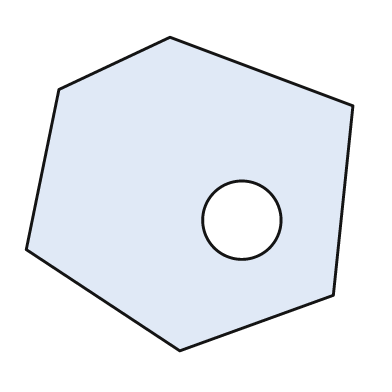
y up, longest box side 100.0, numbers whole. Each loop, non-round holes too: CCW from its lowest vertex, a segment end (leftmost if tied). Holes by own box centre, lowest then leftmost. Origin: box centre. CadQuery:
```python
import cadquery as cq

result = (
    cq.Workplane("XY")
    .moveTo(-3.0, -48.0)
    .lineTo(44.0, -31.0)
    .lineTo(50.0, 27.0)
    .lineTo(-6.0, 48.0)
    .lineTo(-40.0, 32.0)
    .lineTo(-50.0, -17.0)
    .close()
    .moveTo(16.0, -8.0)
    .circle(12.0)
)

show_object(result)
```